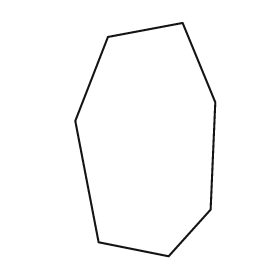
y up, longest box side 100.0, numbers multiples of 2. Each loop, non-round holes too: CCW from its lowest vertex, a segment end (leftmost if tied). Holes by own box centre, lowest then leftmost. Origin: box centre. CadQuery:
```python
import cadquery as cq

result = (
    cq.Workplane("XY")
    .moveTo(10.0, -50.0)
    .lineTo(28.0, -30.0)
    .lineTo(30.0, 16.0)
    .lineTo(16.0, 50.0)
    .lineTo(-16.0, 44.0)
    .lineTo(-30.0, 8.0)
    .lineTo(-20.0, -44.0)
    .close()
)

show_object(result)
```